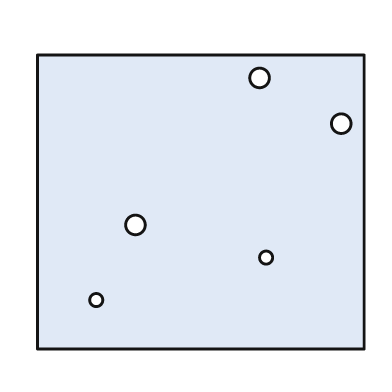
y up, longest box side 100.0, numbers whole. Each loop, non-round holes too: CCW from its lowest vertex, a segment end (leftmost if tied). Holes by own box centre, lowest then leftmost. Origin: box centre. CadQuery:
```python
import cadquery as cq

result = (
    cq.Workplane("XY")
    .moveTo(-50.0, -45.0)
    .lineTo(50.0, -45.0)
    .lineTo(50.0, 45.0)
    .lineTo(-50.0, 45.0)
    .close()
    .moveTo(-32.0, -30.0)
    .circle(2.0)
    .moveTo(20.0, -17.0)
    .circle(2.0)
    .moveTo(-20.0, -7.0)
    .circle(3.0)
    .moveTo(43.0, 24.0)
    .circle(3.0)
    .moveTo(18.0, 38.0)
    .circle(3.0)
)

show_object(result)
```